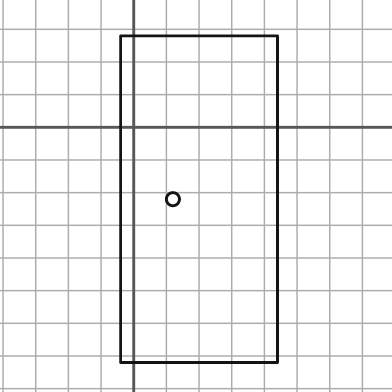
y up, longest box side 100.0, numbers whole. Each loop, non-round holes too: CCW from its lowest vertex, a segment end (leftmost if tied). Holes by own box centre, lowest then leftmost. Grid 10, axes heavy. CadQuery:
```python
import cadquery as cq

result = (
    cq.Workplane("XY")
    .moveTo(-4.0, -72.0)
    .lineTo(44.0, -72.0)
    .lineTo(44.0, 28.0)
    .lineTo(-4.0, 28.0)
    .close()
    .moveTo(12.0, -22.0)
    .circle(2.0)
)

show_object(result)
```